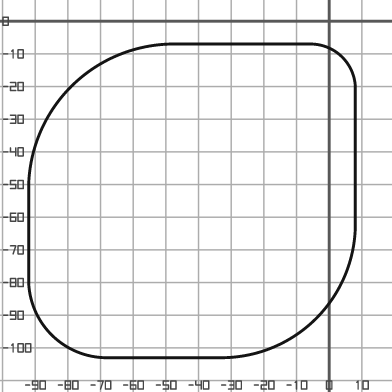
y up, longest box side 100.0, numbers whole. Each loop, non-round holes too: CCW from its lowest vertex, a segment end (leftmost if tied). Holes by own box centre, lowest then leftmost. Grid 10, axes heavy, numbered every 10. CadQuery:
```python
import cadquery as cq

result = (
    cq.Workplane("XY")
    .moveTo(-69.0, -103.0)
    .lineTo(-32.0, -103.0)
    .threePointArc((-4.0, -91.0), (8.0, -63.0))
    .lineTo(8.0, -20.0)
    .threePointArc((4.0, -11.0), (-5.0, -7.0))
    .lineTo(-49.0, -7.0)
    .threePointArc((-79.0, -20.0), (-92.0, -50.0))
    .lineTo(-92.0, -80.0)
    .threePointArc((-85.0, -96.0), (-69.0, -103.0))
    .close()
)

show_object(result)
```